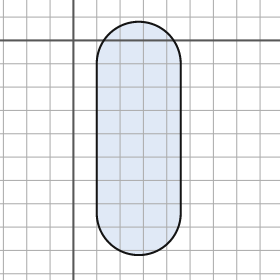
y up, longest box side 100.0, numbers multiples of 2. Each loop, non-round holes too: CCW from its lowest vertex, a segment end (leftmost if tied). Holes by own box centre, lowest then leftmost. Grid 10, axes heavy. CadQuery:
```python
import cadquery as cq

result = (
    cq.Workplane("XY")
    .moveTo(10.0, -74.0)
    .threePointArc((28.0, -92.0), (46.0, -74.0))
    .lineTo(46.0, -10.0)
    .threePointArc((28.0, 8.0), (10.0, -10.0))
    .close()
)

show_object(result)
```